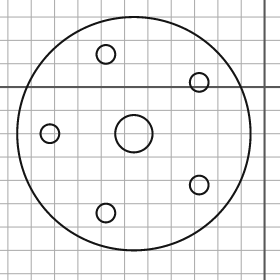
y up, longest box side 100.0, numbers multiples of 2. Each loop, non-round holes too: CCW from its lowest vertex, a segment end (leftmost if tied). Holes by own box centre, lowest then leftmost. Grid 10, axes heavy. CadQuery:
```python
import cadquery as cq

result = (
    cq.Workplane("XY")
    .moveTo(-56.0, -20.0)
    .circle(50.0)
    .moveTo(-68.0, -54.0)
    .circle(4.0)
    .moveTo(-28.0, -42.0)
    .circle(4.0)
    .moveTo(-92.0, -20.0)
    .circle(4.0)
    .moveTo(-56.0, -20.0)
    .circle(8.0)
    .moveTo(-28.0, 2.0)
    .circle(4.0)
    .moveTo(-68.0, 14.0)
    .circle(4.0)
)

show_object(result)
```